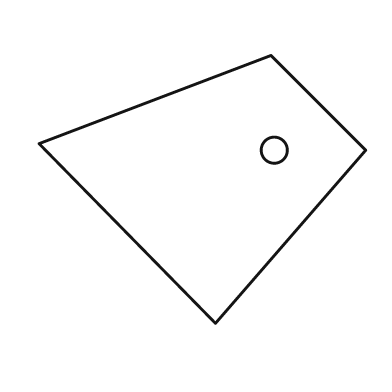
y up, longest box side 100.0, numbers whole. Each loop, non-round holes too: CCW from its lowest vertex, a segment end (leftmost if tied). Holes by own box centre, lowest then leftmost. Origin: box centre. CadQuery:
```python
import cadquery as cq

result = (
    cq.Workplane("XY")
    .moveTo(4.0, -41.0)
    .lineTo(50.0, 12.0)
    .lineTo(21.0, 41.0)
    .lineTo(-50.0, 14.0)
    .close()
    .moveTo(22.0, 12.0)
    .circle(4.0)
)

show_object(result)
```